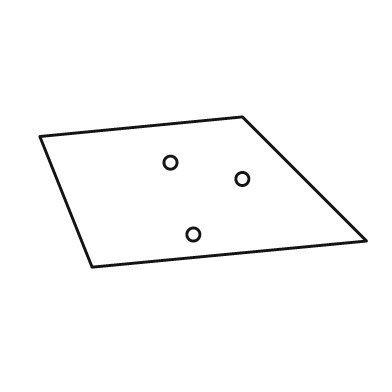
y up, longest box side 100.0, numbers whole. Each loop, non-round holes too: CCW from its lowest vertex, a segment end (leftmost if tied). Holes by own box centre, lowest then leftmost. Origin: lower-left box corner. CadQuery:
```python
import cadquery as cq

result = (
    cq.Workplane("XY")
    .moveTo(16.0, 0.0)
    .lineTo(100.0, 8.0)
    .lineTo(62.0, 46.0)
    .lineTo(0.0, 40.0)
    .close()
    .moveTo(47.0, 10.0)
    .circle(2.0)
    .moveTo(62.0, 27.0)
    .circle(2.0)
    .moveTo(40.0, 32.0)
    .circle(2.0)
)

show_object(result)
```